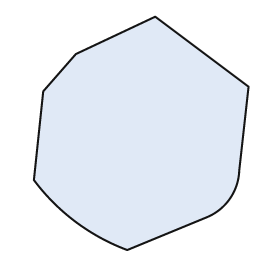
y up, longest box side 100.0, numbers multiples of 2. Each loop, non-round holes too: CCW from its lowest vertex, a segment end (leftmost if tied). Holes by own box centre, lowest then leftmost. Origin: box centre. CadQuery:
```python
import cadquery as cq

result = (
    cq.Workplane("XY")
    .moveTo(-6.0, -50.0)
    .lineTo(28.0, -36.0)
    .threePointArc((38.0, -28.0), (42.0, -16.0))
    .lineTo(46.0, 20.0)
    .lineTo(6.0, 50.0)
    .lineTo(-28.0, 34.0)
    .lineTo(-42.0, 18.0)
    .lineTo(-46.0, -20.0)
    .threePointArc((-28.0, -38.0), (-6.0, -50.0))
    .close()
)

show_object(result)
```